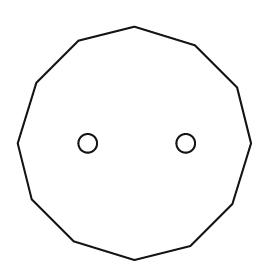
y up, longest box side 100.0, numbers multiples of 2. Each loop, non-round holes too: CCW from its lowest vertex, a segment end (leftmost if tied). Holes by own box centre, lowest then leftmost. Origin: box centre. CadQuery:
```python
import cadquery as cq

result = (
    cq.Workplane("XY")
    .moveTo(0.0, -50.0)
    .lineTo(24.0, -44.0)
    .lineTo(42.0, -26.0)
    .lineTo(50.0, 0.0)
    .lineTo(44.0, 24.0)
    .lineTo(26.0, 42.0)
    .lineTo(0.0, 50.0)
    .lineTo(-24.0, 44.0)
    .lineTo(-42.0, 26.0)
    .lineTo(-50.0, 0.0)
    .lineTo(-44.0, -24.0)
    .lineTo(-26.0, -42.0)
    .close()
    .moveTo(-20.0, 0.0)
    .circle(4.0)
    .moveTo(22.0, 0.0)
    .circle(4.0)
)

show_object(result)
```